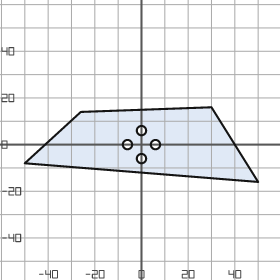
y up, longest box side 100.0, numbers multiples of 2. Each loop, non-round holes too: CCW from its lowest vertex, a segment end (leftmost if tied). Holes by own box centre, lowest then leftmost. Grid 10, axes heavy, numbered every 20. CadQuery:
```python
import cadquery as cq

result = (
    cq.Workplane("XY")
    .moveTo(50.0, -16.0)
    .lineTo(30.0, 16.0)
    .lineTo(-26.0, 14.0)
    .lineTo(-50.0, -8.0)
    .close()
    .moveTo(0.0, -6.0)
    .circle(2.0)
    .moveTo(-6.0, 0.0)
    .circle(2.0)
    .moveTo(6.0, 0.0)
    .circle(2.0)
    .moveTo(0.0, 6.0)
    .circle(2.0)
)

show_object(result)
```